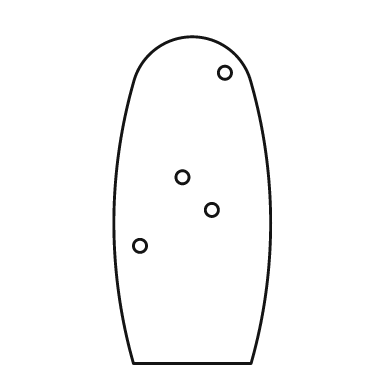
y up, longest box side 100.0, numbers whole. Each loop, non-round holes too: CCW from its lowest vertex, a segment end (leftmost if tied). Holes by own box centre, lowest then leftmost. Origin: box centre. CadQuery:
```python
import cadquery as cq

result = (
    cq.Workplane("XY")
    .moveTo(-18.0, -50.0)
    .lineTo(18.0, -50.0)
    .threePointArc((24.0, -7.0), (18.0, 36.0))
    .threePointArc((0.0, 50.0), (-18.0, 36.0))
    .threePointArc((-24.0, -7.0), (-18.0, -50.0))
    .close()
    .moveTo(-16.0, -14.0)
    .circle(2.0)
    .moveTo(6.0, -3.0)
    .circle(2.0)
    .moveTo(-3.0, 7.0)
    .circle(2.0)
    .moveTo(10.0, 39.0)
    .circle(2.0)
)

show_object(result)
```